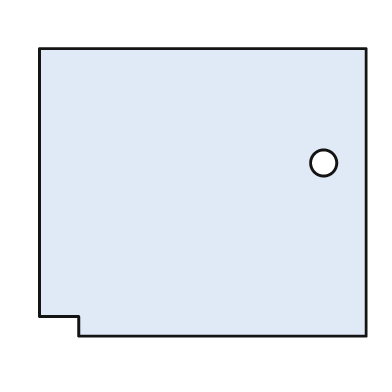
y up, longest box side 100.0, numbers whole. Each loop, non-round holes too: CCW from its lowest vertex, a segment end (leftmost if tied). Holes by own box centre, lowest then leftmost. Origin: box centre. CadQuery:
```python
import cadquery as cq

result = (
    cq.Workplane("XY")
    .moveTo(-38.0, -44.0)
    .lineTo(50.0, -44.0)
    .lineTo(50.0, 44.0)
    .lineTo(-50.0, 44.0)
    .lineTo(-50.0, -38.0)
    .lineTo(-38.0, -38.0)
    .close()
    .moveTo(37.0, 9.0)
    .circle(4.0)
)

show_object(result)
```